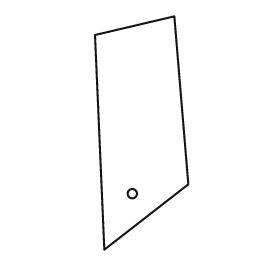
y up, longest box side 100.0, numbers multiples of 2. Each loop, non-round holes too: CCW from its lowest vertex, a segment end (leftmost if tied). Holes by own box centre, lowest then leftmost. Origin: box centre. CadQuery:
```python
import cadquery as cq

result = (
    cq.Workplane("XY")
    .moveTo(-16.0, -50.0)
    .lineTo(20.0, -22.0)
    .lineTo(14.0, 50.0)
    .lineTo(-20.0, 42.0)
    .close()
    .moveTo(-4.0, -26.0)
    .circle(2.0)
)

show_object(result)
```